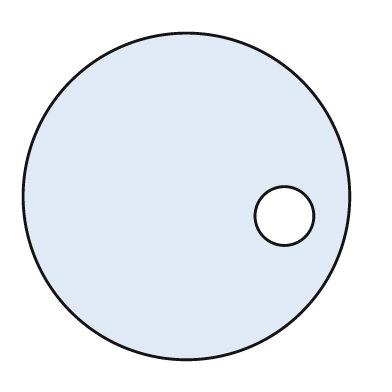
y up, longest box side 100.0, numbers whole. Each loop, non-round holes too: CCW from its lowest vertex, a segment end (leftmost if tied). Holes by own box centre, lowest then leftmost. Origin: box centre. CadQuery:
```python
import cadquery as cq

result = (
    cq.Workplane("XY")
    .moveTo(0.0, 0.0)
    .circle(50.0)
    .moveTo(30.0, -6.0)
    .circle(9.0)
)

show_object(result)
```